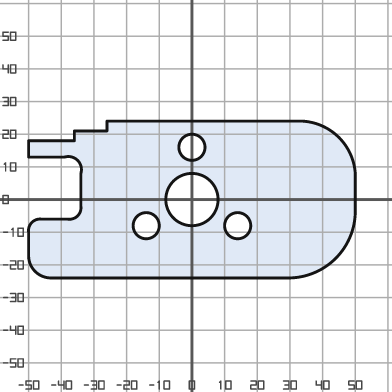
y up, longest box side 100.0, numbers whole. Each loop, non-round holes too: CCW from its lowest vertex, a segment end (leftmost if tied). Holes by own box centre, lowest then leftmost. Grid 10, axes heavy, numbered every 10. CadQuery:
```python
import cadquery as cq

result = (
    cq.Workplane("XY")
    .moveTo(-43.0, -24.0)
    .lineTo(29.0, -24.0)
    .threePointArc((44.0, -18.0), (50.0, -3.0))
    .lineTo(50.0, 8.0)
    .threePointArc((45.0, 19.0), (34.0, 24.0))
    .lineTo(-26.0, 24.0)
    .lineTo(-26.0, 21.0)
    .lineTo(-36.0, 21.0)
    .lineTo(-36.0, 18.0)
    .lineTo(-50.0, 18.0)
    .lineTo(-50.0, 13.0)
    .lineTo(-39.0, 13.0)
    .threePointArc((-35.0, 12.0), (-34.0, 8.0))
    .lineTo(-34.0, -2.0)
    .threePointArc((-35.0, -5.0), (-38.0, -6.0))
    .lineTo(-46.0, -6.0)
    .threePointArc((-49.0, -7.0), (-50.0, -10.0))
    .lineTo(-50.0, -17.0)
    .threePointArc((-48.0, -22.0), (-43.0, -24.0))
    .close()
    .moveTo(-14.0, -8.0)
    .circle(4.0)
    .moveTo(14.0, -8.0)
    .circle(4.0)
    .moveTo(0.0, 0.0)
    .circle(8.0)
    .moveTo(0.0, 16.0)
    .circle(4.0)
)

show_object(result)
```